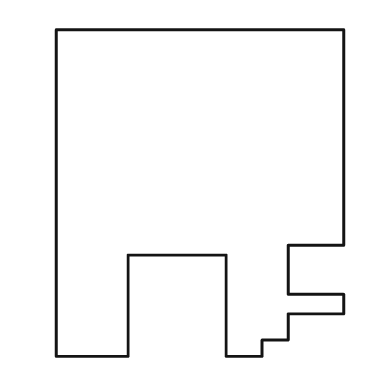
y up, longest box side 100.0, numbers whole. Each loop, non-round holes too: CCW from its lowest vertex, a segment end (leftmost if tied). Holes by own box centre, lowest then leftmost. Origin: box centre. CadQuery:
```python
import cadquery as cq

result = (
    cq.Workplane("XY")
    .moveTo(-44.0, -50.0)
    .lineTo(-22.0, -50.0)
    .lineTo(-22.0, -19.0)
    .lineTo(8.0, -19.0)
    .lineTo(8.0, -50.0)
    .lineTo(19.0, -50.0)
    .lineTo(19.0, -45.0)
    .lineTo(27.0, -45.0)
    .lineTo(27.0, -37.0)
    .lineTo(44.0, -37.0)
    .lineTo(44.0, -31.0)
    .lineTo(27.0, -31.0)
    .lineTo(27.0, -16.0)
    .lineTo(44.0, -16.0)
    .lineTo(44.0, 50.0)
    .lineTo(-44.0, 50.0)
    .close()
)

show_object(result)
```